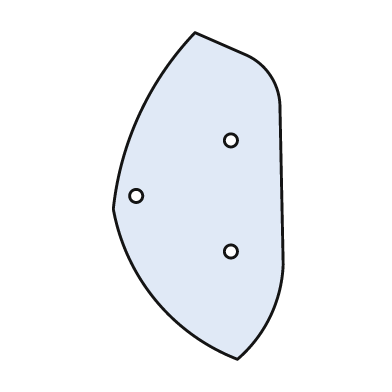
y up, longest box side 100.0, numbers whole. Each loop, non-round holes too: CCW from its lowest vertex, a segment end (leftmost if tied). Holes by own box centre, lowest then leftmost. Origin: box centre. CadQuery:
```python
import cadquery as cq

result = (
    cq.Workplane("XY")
    .moveTo(12.0, -50.0)
    .threePointArc((22.0, -37.0), (26.0, -21.0))
    .lineTo(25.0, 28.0)
    .threePointArc((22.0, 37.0), (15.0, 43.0))
    .lineTo(-1.0, 50.0)
    .threePointArc((-18.0, 25.0), (-26.0, -4.0))
    .threePointArc((-13.0, -32.0), (12.0, -50.0))
    .close()
    .moveTo(10.0, -17.0)
    .circle(2.0)
    .moveTo(-19.0, 0.0)
    .circle(2.0)
    .moveTo(10.0, 17.0)
    .circle(2.0)
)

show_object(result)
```